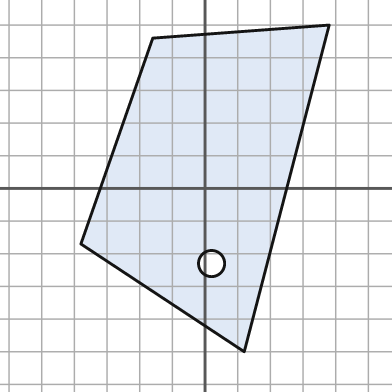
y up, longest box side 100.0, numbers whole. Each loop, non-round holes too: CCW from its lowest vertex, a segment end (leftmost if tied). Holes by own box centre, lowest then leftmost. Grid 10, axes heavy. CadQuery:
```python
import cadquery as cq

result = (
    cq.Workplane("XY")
    .moveTo(12.0, -50.0)
    .lineTo(38.0, 50.0)
    .lineTo(-16.0, 46.0)
    .lineTo(-38.0, -17.0)
    .close()
    .moveTo(2.0, -23.0)
    .circle(4.0)
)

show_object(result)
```